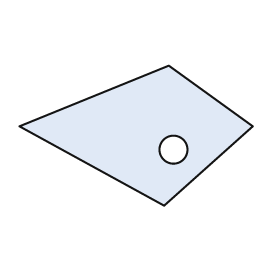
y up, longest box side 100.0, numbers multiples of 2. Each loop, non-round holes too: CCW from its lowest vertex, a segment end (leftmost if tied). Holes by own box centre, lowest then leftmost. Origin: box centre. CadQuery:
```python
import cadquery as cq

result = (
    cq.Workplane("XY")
    .moveTo(12.0, -30.0)
    .lineTo(50.0, 4.0)
    .lineTo(14.0, 30.0)
    .lineTo(-50.0, 4.0)
    .close()
    .moveTo(16.0, -6.0)
    .circle(6.0)
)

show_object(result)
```